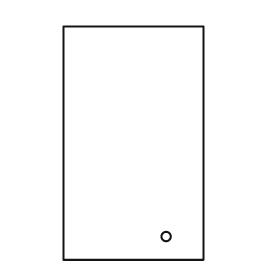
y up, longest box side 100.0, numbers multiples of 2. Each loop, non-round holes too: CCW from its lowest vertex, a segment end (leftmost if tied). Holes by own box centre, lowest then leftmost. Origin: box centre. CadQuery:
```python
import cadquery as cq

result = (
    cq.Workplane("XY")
    .moveTo(-30.0, -50.0)
    .lineTo(30.0, -50.0)
    .lineTo(30.0, 50.0)
    .lineTo(-30.0, 50.0)
    .close()
    .moveTo(14.0, -40.0)
    .circle(2.0)
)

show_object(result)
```